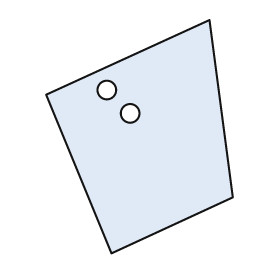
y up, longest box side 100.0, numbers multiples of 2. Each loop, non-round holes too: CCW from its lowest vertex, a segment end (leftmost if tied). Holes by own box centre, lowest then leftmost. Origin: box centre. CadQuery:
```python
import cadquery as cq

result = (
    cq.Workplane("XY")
    .moveTo(-12.0, -50.0)
    .lineTo(40.0, -26.0)
    .lineTo(30.0, 50.0)
    .lineTo(-40.0, 18.0)
    .close()
    .moveTo(-4.0, 10.0)
    .circle(4.0)
    .moveTo(-14.0, 20.0)
    .circle(4.0)
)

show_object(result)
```